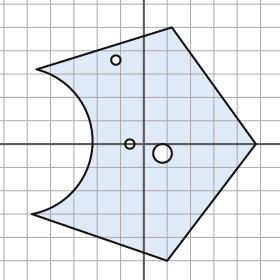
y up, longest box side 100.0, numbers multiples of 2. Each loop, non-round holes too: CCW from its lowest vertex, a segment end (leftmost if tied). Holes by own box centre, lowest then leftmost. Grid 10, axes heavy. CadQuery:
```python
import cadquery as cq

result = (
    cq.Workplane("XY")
    .moveTo(10.0, -50.0)
    .lineTo(48.0, 0.0)
    .lineTo(12.0, 50.0)
    .lineTo(-46.0, 32.0)
    .threePointArc((-22.0, 0.0), (-48.0, -30.0))
    .close()
    .moveTo(8.0, -4.0)
    .circle(4.0)
    .moveTo(-6.0, 0.0)
    .circle(2.0)
    .moveTo(-12.0, 36.0)
    .circle(2.0)
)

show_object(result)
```